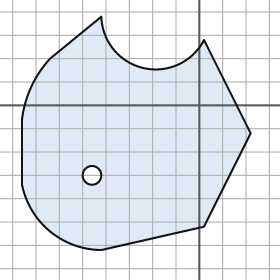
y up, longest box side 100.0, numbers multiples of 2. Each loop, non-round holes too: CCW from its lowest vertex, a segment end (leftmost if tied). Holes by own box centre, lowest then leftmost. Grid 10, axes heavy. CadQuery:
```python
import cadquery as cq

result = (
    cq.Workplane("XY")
    .moveTo(-42.0, -62.0)
    .lineTo(2.0, -52.0)
    .lineTo(22.0, -12.0)
    .lineTo(2.0, 28.0)
    .threePointArc((-24.0, 16.0), (-42.0, 38.0))
    .lineTo(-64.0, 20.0)
    .threePointArc((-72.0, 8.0), (-76.0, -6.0))
    .lineTo(-76.0, -34.0)
    .threePointArc((-64.0, -54.0), (-42.0, -62.0))
    .close()
    .moveTo(-46.0, -30.0)
    .circle(4.0)
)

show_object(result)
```